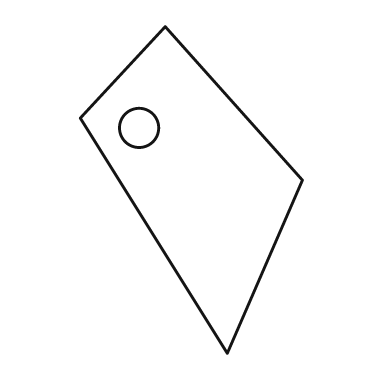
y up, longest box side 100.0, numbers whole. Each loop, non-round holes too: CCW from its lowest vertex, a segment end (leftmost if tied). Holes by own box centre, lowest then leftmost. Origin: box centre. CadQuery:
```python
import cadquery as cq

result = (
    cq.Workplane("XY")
    .moveTo(11.0, -50.0)
    .lineTo(34.0, 3.0)
    .lineTo(-8.0, 50.0)
    .lineTo(-34.0, 22.0)
    .close()
    .moveTo(-16.0, 19.0)
    .circle(6.0)
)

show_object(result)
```